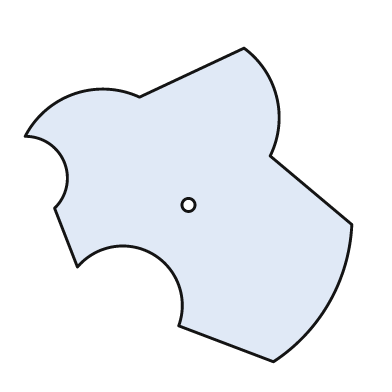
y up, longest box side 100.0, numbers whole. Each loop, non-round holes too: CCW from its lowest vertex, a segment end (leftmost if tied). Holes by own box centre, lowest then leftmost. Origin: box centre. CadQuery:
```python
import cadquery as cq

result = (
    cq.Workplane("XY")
    .moveTo(26.0, -48.0)
    .threePointArc((43.0, -30.0), (50.0, -6.0))
    .lineTo(25.0, 15.0)
    .threePointArc((27.0, 33.0), (17.0, 48.0))
    .lineTo(-15.0, 33.0)
    .threePointArc((-35.0, 34.0), (-50.0, 21.0))
    .threePointArc((-38.0, 13.0), (-41.0, -1.0))
    .lineTo(-34.0, -19.0)
    .threePointArc((-11.0, -15.0), (-3.0, -37.0))
    .close()
    .moveTo(0.0, 0.0)
    .circle(2.0)
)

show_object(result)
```